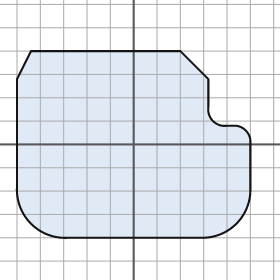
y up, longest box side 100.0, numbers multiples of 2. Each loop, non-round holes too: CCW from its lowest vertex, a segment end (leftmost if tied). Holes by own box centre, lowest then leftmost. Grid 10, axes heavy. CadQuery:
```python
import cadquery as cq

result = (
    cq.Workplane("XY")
    .moveTo(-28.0, -40.0)
    .lineTo(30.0, -40.0)
    .threePointArc((44.0, -34.0), (50.0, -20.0))
    .lineTo(50.0, 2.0)
    .threePointArc((48.0, 6.0), (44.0, 8.0))
    .lineTo(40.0, 8.0)
    .threePointArc((34.0, 10.0), (32.0, 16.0))
    .lineTo(32.0, 28.0)
    .lineTo(20.0, 40.0)
    .lineTo(-44.0, 40.0)
    .lineTo(-50.0, 28.0)
    .lineTo(-50.0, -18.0)
    .threePointArc((-44.0, -34.0), (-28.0, -40.0))
    .close()
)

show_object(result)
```